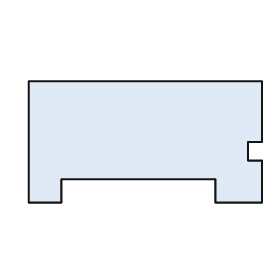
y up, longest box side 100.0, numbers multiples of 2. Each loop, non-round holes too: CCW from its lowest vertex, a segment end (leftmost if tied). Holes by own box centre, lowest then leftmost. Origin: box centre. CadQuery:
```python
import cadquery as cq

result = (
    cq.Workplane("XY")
    .moveTo(-50.0, -26.0)
    .lineTo(-36.0, -26.0)
    .lineTo(-36.0, -16.0)
    .lineTo(30.0, -16.0)
    .lineTo(30.0, -26.0)
    .lineTo(50.0, -26.0)
    .lineTo(50.0, -8.0)
    .lineTo(44.0, -8.0)
    .lineTo(44.0, 0.0)
    .lineTo(50.0, 0.0)
    .lineTo(50.0, 26.0)
    .lineTo(-50.0, 26.0)
    .close()
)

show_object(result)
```